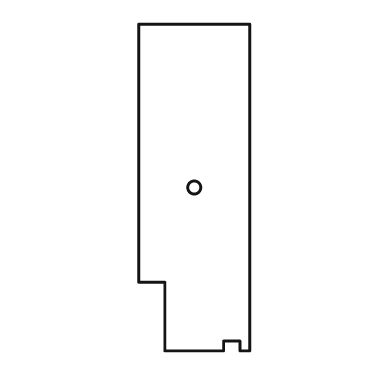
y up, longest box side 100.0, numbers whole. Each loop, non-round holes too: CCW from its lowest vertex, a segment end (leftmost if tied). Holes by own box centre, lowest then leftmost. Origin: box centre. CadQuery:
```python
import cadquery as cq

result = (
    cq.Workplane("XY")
    .moveTo(-9.0, -50.0)
    .lineTo(9.0, -50.0)
    .lineTo(9.0, -47.0)
    .lineTo(14.0, -47.0)
    .lineTo(14.0, -50.0)
    .lineTo(17.0, -50.0)
    .lineTo(17.0, 50.0)
    .lineTo(-17.0, 50.0)
    .lineTo(-17.0, -29.0)
    .lineTo(-9.0, -29.0)
    .close()
    .moveTo(0.0, 0.0)
    .circle(2.0)
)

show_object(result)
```